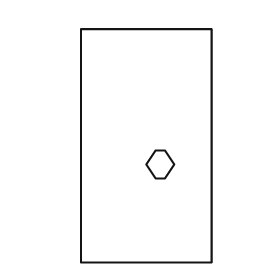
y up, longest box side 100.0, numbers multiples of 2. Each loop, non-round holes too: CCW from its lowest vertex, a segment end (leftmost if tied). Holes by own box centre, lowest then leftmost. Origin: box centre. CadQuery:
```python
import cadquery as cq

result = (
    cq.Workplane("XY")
    .moveTo(-28.0, -50.0)
    .lineTo(28.0, -50.0)
    .lineTo(28.0, 50.0)
    .lineTo(-28.0, 50.0)
    .close()
    .moveTo(4.0, -14.0)
    .lineTo(8.0, -14.0)
    .lineTo(12.0, -8.0)
    .lineTo(8.0, -2.0)
    .lineTo(4.0, -2.0)
    .lineTo(0.0, -8.0)
    .close()
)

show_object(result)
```